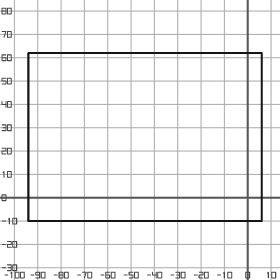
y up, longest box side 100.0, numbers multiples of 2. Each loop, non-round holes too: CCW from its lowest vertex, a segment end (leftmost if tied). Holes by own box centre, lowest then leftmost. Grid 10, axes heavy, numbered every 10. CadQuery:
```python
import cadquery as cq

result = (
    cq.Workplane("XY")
    .moveTo(-94.0, -10.0)
    .lineTo(6.0, -10.0)
    .lineTo(6.0, 62.0)
    .lineTo(-94.0, 62.0)
    .close()
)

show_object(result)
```